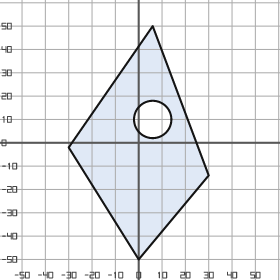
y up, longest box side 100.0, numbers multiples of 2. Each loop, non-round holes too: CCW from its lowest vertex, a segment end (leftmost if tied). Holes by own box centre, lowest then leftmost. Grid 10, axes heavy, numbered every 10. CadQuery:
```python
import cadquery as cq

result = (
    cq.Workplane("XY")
    .moveTo(0.0, -50.0)
    .lineTo(30.0, -14.0)
    .lineTo(6.0, 50.0)
    .lineTo(-30.0, -2.0)
    .close()
    .moveTo(6.0, 10.0)
    .circle(8.0)
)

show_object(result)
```